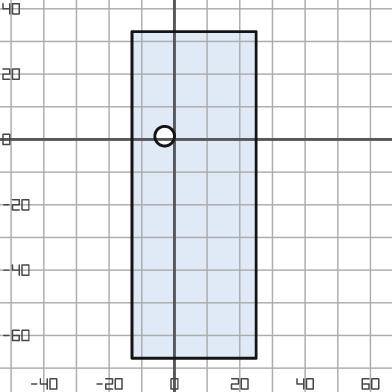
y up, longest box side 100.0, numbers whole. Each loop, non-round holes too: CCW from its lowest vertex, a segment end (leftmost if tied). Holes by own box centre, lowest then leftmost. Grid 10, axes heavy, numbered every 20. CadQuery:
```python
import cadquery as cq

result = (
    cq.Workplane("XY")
    .moveTo(-13.0, -67.0)
    .lineTo(25.0, -67.0)
    .lineTo(25.0, 33.0)
    .lineTo(-13.0, 33.0)
    .close()
    .moveTo(-3.0, 1.0)
    .circle(3.0)
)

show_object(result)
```